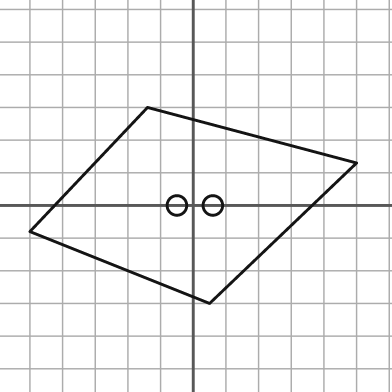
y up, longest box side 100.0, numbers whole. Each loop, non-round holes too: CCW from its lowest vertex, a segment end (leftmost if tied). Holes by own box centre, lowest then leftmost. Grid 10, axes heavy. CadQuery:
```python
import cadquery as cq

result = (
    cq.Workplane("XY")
    .moveTo(5.0, -30.0)
    .lineTo(50.0, 13.0)
    .lineTo(-14.0, 30.0)
    .lineTo(-50.0, -8.0)
    .close()
    .moveTo(-5.0, 0.0)
    .circle(3.0)
    .moveTo(6.0, 0.0)
    .circle(3.0)
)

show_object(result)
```